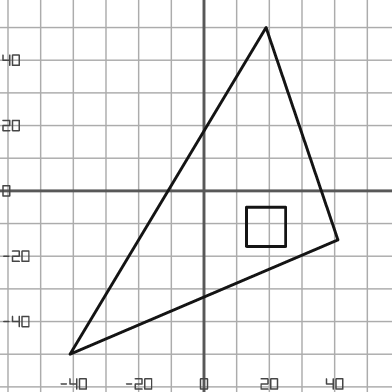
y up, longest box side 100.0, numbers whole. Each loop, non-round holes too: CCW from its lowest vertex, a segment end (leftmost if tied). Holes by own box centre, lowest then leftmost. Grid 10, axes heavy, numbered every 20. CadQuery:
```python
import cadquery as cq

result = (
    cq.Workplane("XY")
    .moveTo(-41.0, -50.0)
    .lineTo(41.0, -15.0)
    .lineTo(19.0, 50.0)
    .close()
    .moveTo(13.0, -17.0)
    .lineTo(25.0, -17.0)
    .lineTo(25.0, -5.0)
    .lineTo(13.0, -5.0)
    .close()
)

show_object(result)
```